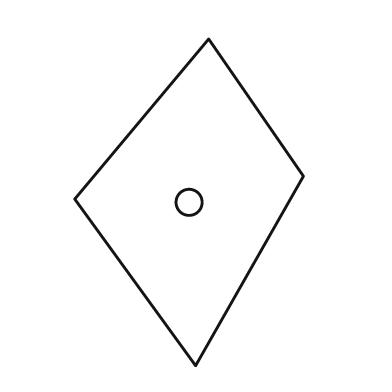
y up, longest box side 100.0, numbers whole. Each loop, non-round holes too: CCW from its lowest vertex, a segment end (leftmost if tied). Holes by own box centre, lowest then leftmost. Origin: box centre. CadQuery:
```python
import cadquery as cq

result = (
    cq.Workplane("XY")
    .moveTo(2.0, -50.0)
    .lineTo(35.0, 8.0)
    .lineTo(6.0, 50.0)
    .lineTo(-35.0, 1.0)
    .close()
    .moveTo(0.0, 0.0)
    .circle(4.0)
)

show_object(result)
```